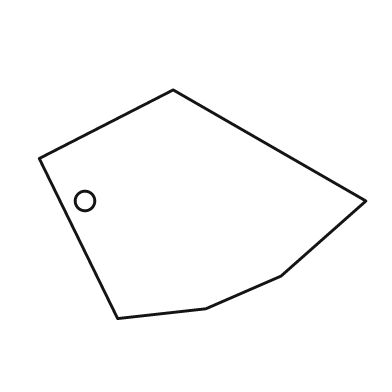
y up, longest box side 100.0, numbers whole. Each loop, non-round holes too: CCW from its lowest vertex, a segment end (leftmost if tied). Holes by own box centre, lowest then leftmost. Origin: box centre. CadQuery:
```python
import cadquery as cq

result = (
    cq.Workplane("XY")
    .moveTo(-26.0, -35.0)
    .lineTo(1.0, -32.0)
    .lineTo(24.0, -22.0)
    .lineTo(50.0, 1.0)
    .lineTo(-9.0, 35.0)
    .lineTo(-50.0, 14.0)
    .close()
    .moveTo(-36.0, 1.0)
    .circle(3.0)
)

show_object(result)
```